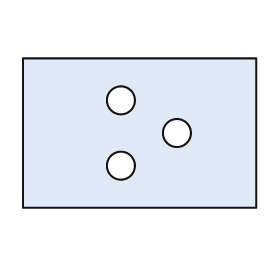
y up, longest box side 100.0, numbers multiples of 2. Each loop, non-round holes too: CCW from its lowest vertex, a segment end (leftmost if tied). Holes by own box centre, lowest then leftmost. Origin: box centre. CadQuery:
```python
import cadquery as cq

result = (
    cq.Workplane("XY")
    .moveTo(-50.0, -32.0)
    .lineTo(50.0, -32.0)
    .lineTo(50.0, 32.0)
    .lineTo(-50.0, 32.0)
    .close()
    .moveTo(-8.0, -14.0)
    .circle(6.0)
    .moveTo(16.0, 0.0)
    .circle(6.0)
    .moveTo(-8.0, 14.0)
    .circle(6.0)
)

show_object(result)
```